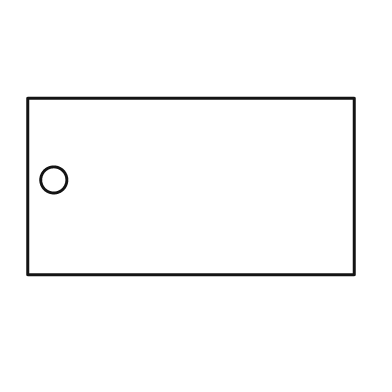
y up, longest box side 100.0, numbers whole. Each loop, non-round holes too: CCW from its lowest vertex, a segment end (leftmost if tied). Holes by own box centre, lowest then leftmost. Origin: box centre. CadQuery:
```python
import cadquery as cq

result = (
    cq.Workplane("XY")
    .moveTo(-50.0, -27.0)
    .lineTo(50.0, -27.0)
    .lineTo(50.0, 27.0)
    .lineTo(-50.0, 27.0)
    .close()
    .moveTo(-42.0, 2.0)
    .circle(4.0)
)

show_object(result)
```